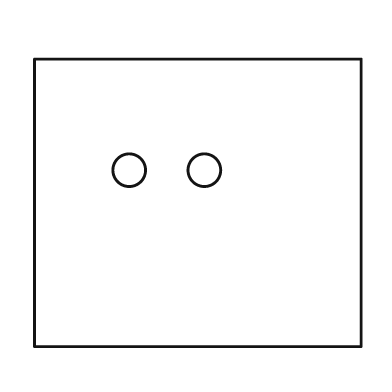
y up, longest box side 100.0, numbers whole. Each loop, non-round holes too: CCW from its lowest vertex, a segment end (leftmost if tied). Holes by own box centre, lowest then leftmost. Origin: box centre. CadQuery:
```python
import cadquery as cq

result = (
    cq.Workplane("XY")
    .moveTo(-50.0, -44.0)
    .lineTo(50.0, -44.0)
    .lineTo(50.0, 44.0)
    .lineTo(-50.0, 44.0)
    .close()
    .moveTo(-21.0, 10.0)
    .circle(5.0)
    .moveTo(2.0, 10.0)
    .circle(5.0)
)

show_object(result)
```